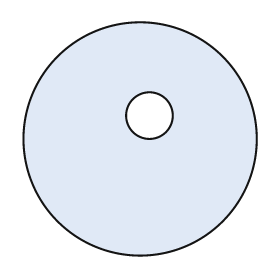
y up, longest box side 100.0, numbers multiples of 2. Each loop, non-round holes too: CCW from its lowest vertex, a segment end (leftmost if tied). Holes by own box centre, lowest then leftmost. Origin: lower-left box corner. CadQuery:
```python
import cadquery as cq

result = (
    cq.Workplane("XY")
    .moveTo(50.0, 50.0)
    .circle(50.0)
    .moveTo(54.0, 60.0)
    .circle(10.0)
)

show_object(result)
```